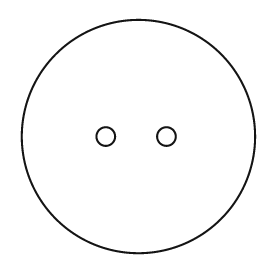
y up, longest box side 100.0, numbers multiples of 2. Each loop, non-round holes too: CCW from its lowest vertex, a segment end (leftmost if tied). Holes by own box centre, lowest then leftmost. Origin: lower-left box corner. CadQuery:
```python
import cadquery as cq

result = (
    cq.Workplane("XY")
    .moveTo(50.0, 50.0)
    .circle(50.0)
    .moveTo(36.0, 50.0)
    .circle(4.0)
    .moveTo(62.0, 50.0)
    .circle(4.0)
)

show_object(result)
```